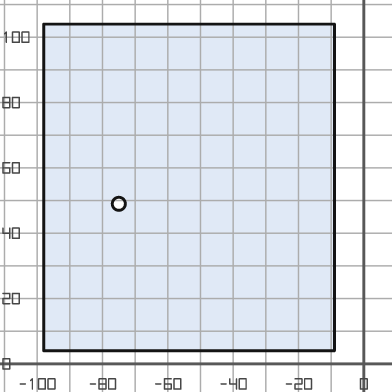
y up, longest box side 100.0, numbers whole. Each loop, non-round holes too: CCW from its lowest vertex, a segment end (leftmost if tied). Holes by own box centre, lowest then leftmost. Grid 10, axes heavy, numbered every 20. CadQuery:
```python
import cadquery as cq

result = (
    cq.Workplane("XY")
    .moveTo(-98.0, 4.0)
    .lineTo(-9.0, 4.0)
    .lineTo(-9.0, 104.0)
    .lineTo(-98.0, 104.0)
    .close()
    .moveTo(-75.0, 49.0)
    .circle(2.0)
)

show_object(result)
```